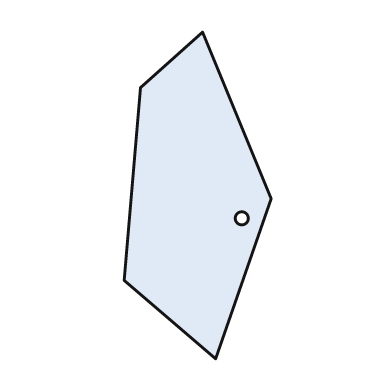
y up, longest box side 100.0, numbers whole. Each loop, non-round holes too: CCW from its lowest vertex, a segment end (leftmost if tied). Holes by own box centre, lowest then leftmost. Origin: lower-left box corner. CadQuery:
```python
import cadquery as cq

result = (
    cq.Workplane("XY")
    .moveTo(28.0, 0.0)
    .lineTo(45.0, 49.0)
    .lineTo(24.0, 100.0)
    .lineTo(5.0, 83.0)
    .lineTo(0.0, 24.0)
    .close()
    .moveTo(36.0, 43.0)
    .circle(2.0)
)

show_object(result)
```